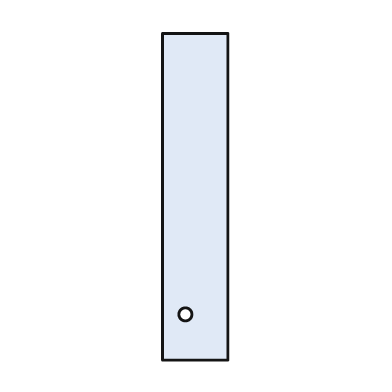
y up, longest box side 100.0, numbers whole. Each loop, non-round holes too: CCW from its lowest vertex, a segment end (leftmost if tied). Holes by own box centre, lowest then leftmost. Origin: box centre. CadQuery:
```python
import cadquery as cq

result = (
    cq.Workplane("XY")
    .moveTo(-10.0, -50.0)
    .lineTo(10.0, -50.0)
    .lineTo(10.0, 50.0)
    .lineTo(-10.0, 50.0)
    .close()
    .moveTo(-3.0, -36.0)
    .circle(2.0)
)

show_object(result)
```